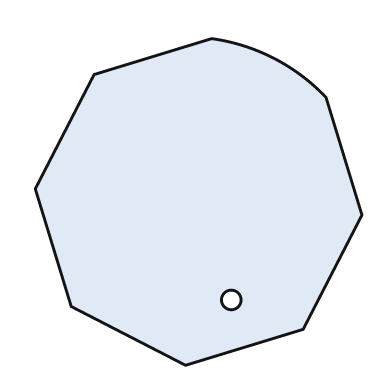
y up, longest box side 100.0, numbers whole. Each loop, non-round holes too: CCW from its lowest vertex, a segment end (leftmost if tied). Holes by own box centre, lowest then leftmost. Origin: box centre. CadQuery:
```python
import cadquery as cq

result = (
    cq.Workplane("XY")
    .moveTo(-4.0, -50.0)
    .lineTo(32.0, -39.0)
    .lineTo(50.0, -4.0)
    .lineTo(39.0, 32.0)
    .threePointArc((23.0, 44.0), (4.0, 50.0))
    .lineTo(-32.0, 39.0)
    .lineTo(-50.0, 4.0)
    .lineTo(-39.0, -32.0)
    .close()
    .moveTo(10.0, -30.0)
    .circle(3.0)
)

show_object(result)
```